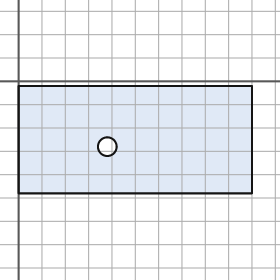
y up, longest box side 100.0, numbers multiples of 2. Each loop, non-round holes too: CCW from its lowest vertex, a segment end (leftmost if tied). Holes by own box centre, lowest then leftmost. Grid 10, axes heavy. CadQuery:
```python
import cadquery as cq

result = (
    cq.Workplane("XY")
    .moveTo(0.0, -48.0)
    .lineTo(100.0, -48.0)
    .lineTo(100.0, -2.0)
    .lineTo(0.0, -2.0)
    .close()
    .moveTo(38.0, -28.0)
    .circle(4.0)
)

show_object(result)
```